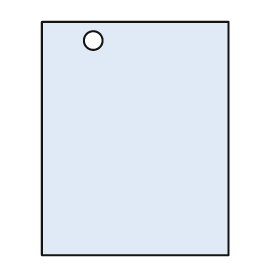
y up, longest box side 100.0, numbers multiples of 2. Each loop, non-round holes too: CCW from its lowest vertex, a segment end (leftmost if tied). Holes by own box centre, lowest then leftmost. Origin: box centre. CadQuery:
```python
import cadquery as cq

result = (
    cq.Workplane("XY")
    .moveTo(-40.0, -50.0)
    .lineTo(40.0, -50.0)
    .lineTo(40.0, 50.0)
    .lineTo(-40.0, 50.0)
    .close()
    .moveTo(-18.0, 42.0)
    .circle(4.0)
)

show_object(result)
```